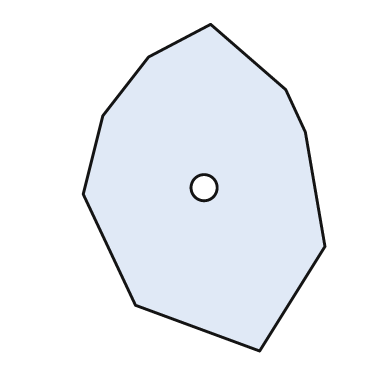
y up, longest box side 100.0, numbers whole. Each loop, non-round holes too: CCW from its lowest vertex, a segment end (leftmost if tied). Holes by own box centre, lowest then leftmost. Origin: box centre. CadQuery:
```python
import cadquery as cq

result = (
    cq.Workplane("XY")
    .moveTo(17.0, -50.0)
    .lineTo(37.0, -18.0)
    .lineTo(31.0, 17.0)
    .lineTo(25.0, 30.0)
    .lineTo(2.0, 50.0)
    .lineTo(-17.0, 40.0)
    .lineTo(-31.0, 22.0)
    .lineTo(-37.0, -2.0)
    .lineTo(-21.0, -36.0)
    .close()
    .moveTo(0.0, 0.0)
    .circle(4.0)
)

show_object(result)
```